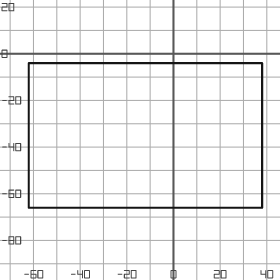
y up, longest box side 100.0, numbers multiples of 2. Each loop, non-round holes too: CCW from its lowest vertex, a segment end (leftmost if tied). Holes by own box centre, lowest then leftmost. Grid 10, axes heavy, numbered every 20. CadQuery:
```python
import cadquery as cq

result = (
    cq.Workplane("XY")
    .moveTo(-62.0, -66.0)
    .lineTo(38.0, -66.0)
    .lineTo(38.0, -4.0)
    .lineTo(-62.0, -4.0)
    .close()
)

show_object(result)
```